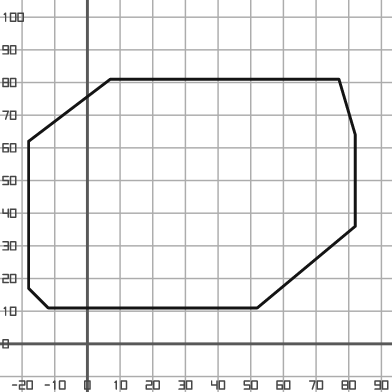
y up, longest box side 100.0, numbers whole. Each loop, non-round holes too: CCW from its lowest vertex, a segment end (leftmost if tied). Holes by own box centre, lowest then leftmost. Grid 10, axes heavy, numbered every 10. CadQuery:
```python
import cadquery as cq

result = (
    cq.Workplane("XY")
    .moveTo(-12.0, 11.0)
    .lineTo(52.0, 11.0)
    .lineTo(82.0, 36.0)
    .lineTo(82.0, 64.0)
    .lineTo(77.0, 81.0)
    .lineTo(7.0, 81.0)
    .lineTo(-18.0, 62.0)
    .lineTo(-18.0, 17.0)
    .close()
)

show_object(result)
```